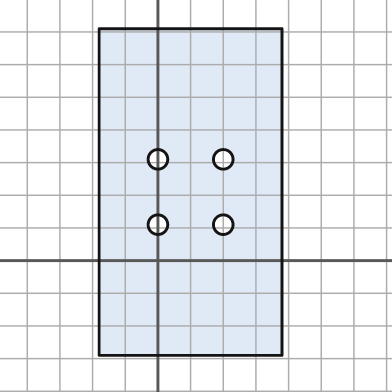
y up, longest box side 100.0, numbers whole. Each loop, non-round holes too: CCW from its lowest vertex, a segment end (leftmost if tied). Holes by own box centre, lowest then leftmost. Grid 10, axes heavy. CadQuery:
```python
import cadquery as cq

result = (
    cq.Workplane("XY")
    .moveTo(-18.0, -29.0)
    .lineTo(38.0, -29.0)
    .lineTo(38.0, 71.0)
    .lineTo(-18.0, 71.0)
    .close()
    .moveTo(0.0, 11.0)
    .circle(3.0)
    .moveTo(20.0, 11.0)
    .circle(3.0)
    .moveTo(0.0, 31.0)
    .circle(3.0)
    .moveTo(20.0, 31.0)
    .circle(3.0)
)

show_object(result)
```